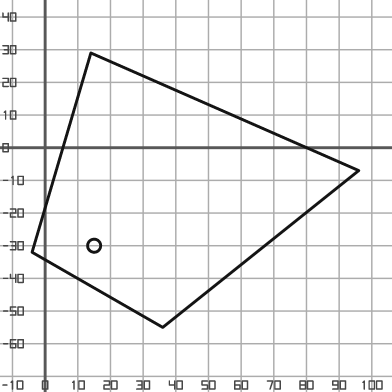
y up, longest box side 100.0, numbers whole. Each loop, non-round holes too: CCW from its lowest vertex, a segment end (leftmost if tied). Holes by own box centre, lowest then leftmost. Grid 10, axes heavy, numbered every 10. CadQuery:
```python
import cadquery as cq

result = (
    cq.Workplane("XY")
    .moveTo(36.0, -55.0)
    .lineTo(96.0, -7.0)
    .lineTo(14.0, 29.0)
    .lineTo(-4.0, -32.0)
    .close()
    .moveTo(15.0, -30.0)
    .circle(2.0)
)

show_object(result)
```